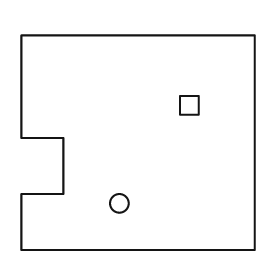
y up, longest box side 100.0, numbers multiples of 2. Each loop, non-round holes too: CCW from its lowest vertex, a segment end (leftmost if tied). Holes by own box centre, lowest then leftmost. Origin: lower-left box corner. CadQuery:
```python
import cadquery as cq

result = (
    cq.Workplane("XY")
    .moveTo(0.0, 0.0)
    .lineTo(100.0, 0.0)
    .lineTo(100.0, 92.0)
    .lineTo(0.0, 92.0)
    .lineTo(0.0, 48.0)
    .lineTo(18.0, 48.0)
    .lineTo(18.0, 24.0)
    .lineTo(0.0, 24.0)
    .close()
    .moveTo(42.0, 20.0)
    .circle(4.0)
    .moveTo(68.0, 58.0)
    .lineTo(76.0, 58.0)
    .lineTo(76.0, 66.0)
    .lineTo(68.0, 66.0)
    .close()
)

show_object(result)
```